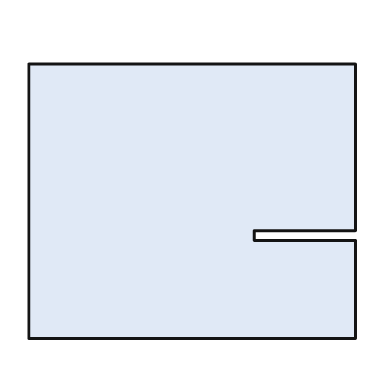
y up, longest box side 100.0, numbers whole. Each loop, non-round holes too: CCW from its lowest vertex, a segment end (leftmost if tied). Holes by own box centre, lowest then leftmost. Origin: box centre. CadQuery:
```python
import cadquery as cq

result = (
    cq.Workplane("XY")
    .moveTo(-50.0, -42.0)
    .lineTo(50.0, -42.0)
    .lineTo(50.0, -12.0)
    .lineTo(19.0, -12.0)
    .lineTo(19.0, -9.0)
    .lineTo(50.0, -9.0)
    .lineTo(50.0, 42.0)
    .lineTo(-50.0, 42.0)
    .close()
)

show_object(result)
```